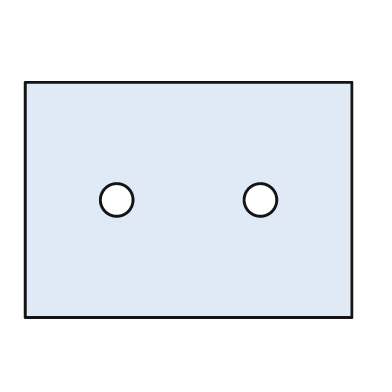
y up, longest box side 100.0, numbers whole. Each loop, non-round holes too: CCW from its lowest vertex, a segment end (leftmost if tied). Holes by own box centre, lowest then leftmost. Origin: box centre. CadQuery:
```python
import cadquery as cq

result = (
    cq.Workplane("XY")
    .moveTo(-50.0, -36.0)
    .lineTo(50.0, -36.0)
    .lineTo(50.0, 36.0)
    .lineTo(-50.0, 36.0)
    .close()
    .moveTo(-22.0, 0.0)
    .circle(5.0)
    .moveTo(22.0, 0.0)
    .circle(5.0)
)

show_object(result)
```